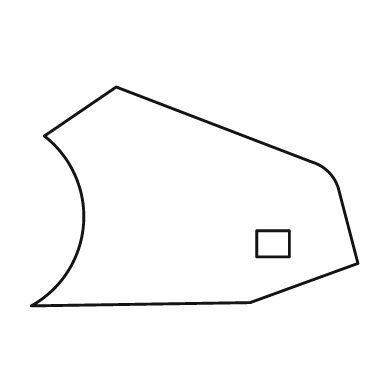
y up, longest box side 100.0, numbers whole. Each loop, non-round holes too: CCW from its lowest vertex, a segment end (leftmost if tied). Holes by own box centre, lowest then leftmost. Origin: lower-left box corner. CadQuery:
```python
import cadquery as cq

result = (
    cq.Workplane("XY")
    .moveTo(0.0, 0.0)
    .lineTo(67.0, 1.0)
    .lineTo(100.0, 13.0)
    .lineTo(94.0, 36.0)
    .threePointArc((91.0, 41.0), (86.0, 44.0))
    .lineTo(26.0, 67.0)
    .lineTo(4.0, 52.0)
    .threePointArc((16.0, 25.0), (0.0, 0.0))
    .close()
    .moveTo(69.0, 15.0)
    .lineTo(79.0, 15.0)
    .lineTo(79.0, 23.0)
    .lineTo(69.0, 23.0)
    .close()
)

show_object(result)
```